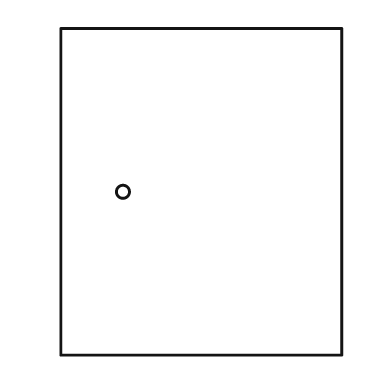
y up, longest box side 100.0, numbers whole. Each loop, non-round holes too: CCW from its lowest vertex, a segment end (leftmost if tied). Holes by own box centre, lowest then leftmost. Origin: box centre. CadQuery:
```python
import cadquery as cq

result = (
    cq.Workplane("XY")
    .moveTo(-43.0, -50.0)
    .lineTo(43.0, -50.0)
    .lineTo(43.0, 50.0)
    .lineTo(-43.0, 50.0)
    .close()
    .moveTo(-24.0, 0.0)
    .circle(2.0)
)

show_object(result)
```